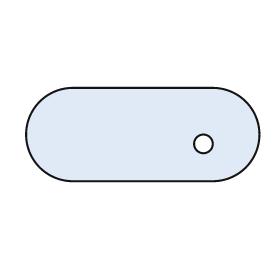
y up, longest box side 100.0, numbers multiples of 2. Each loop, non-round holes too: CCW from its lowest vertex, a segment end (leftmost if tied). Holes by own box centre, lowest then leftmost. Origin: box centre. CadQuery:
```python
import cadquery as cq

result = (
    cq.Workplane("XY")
    .moveTo(-30.0, -20.0)
    .lineTo(30.0, -20.0)
    .threePointArc((50.0, 0.0), (30.0, 20.0))
    .lineTo(-30.0, 20.0)
    .threePointArc((-50.0, 0.0), (-30.0, -20.0))
    .close()
    .moveTo(26.0, -4.0)
    .circle(4.0)
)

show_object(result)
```